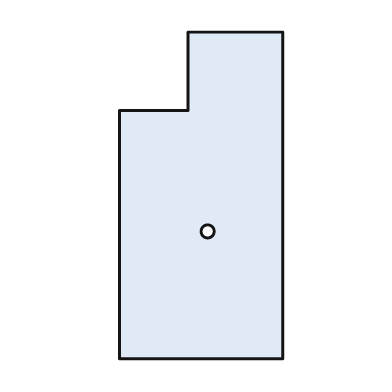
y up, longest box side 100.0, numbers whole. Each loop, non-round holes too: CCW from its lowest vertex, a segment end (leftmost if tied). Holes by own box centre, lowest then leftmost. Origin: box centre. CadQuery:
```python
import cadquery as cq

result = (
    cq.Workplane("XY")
    .moveTo(-25.0, -50.0)
    .lineTo(25.0, -50.0)
    .lineTo(25.0, 50.0)
    .lineTo(-4.0, 50.0)
    .lineTo(-4.0, 26.0)
    .lineTo(-25.0, 26.0)
    .close()
    .moveTo(2.0, -11.0)
    .circle(2.0)
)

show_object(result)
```